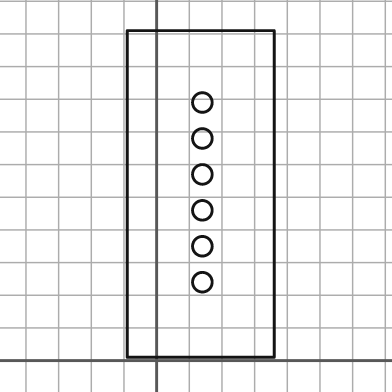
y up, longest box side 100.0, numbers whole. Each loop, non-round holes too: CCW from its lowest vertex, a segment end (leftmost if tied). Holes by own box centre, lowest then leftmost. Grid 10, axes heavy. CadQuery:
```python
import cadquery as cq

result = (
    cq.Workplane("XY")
    .moveTo(-9.0, 1.0)
    .lineTo(36.0, 1.0)
    .lineTo(36.0, 101.0)
    .lineTo(-9.0, 101.0)
    .close()
    .moveTo(14.0, 24.0)
    .circle(3.0)
    .moveTo(14.0, 35.0)
    .circle(3.0)
    .moveTo(14.0, 46.0)
    .circle(3.0)
    .moveTo(14.0, 57.0)
    .circle(3.0)
    .moveTo(14.0, 68.0)
    .circle(3.0)
    .moveTo(14.0, 79.0)
    .circle(3.0)
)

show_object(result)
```